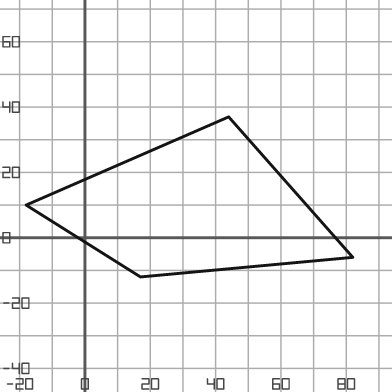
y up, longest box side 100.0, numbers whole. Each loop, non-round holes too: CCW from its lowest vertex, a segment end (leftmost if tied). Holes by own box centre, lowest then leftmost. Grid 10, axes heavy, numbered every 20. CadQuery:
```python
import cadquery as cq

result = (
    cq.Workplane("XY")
    .moveTo(17.0, -12.0)
    .lineTo(82.0, -6.0)
    .lineTo(44.0, 37.0)
    .lineTo(-18.0, 10.0)
    .close()
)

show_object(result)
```